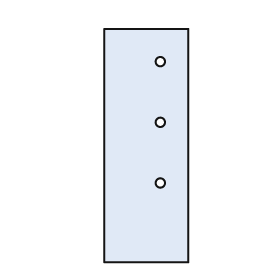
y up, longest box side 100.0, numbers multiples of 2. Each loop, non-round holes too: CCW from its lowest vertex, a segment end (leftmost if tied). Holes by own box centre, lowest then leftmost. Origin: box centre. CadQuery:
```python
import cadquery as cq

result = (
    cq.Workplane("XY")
    .moveTo(-18.0, -50.0)
    .lineTo(18.0, -50.0)
    .lineTo(18.0, 50.0)
    .lineTo(-18.0, 50.0)
    .close()
    .moveTo(6.0, -16.0)
    .circle(2.0)
    .moveTo(6.0, 10.0)
    .circle(2.0)
    .moveTo(6.0, 36.0)
    .circle(2.0)
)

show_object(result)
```